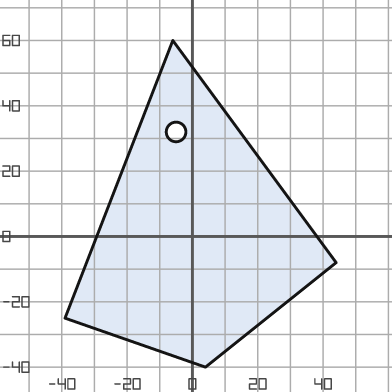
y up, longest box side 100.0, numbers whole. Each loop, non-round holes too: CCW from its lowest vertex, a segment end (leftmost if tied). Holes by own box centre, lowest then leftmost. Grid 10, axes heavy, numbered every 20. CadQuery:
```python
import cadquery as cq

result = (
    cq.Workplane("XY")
    .moveTo(4.0, -40.0)
    .lineTo(44.0, -8.0)
    .lineTo(-6.0, 60.0)
    .lineTo(-39.0, -25.0)
    .close()
    .moveTo(-5.0, 32.0)
    .circle(3.0)
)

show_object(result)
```